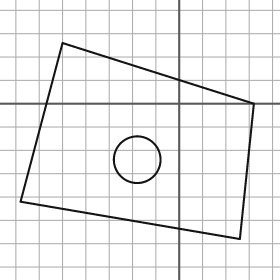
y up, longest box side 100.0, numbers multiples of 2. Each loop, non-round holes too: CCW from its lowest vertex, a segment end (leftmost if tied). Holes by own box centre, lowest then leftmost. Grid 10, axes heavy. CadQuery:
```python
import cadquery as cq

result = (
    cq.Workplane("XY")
    .moveTo(26.0, -58.0)
    .lineTo(32.0, 0.0)
    .lineTo(-50.0, 26.0)
    .lineTo(-68.0, -42.0)
    .close()
    .moveTo(-18.0, -24.0)
    .circle(10.0)
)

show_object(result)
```